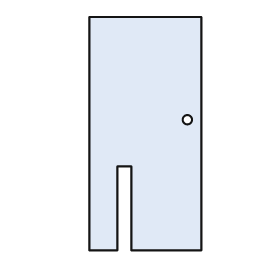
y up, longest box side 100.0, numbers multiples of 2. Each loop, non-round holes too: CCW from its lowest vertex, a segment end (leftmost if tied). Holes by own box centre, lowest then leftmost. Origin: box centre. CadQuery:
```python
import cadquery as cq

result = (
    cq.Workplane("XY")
    .moveTo(-24.0, -50.0)
    .lineTo(-12.0, -50.0)
    .lineTo(-12.0, -14.0)
    .lineTo(-6.0, -14.0)
    .lineTo(-6.0, -50.0)
    .lineTo(24.0, -50.0)
    .lineTo(24.0, 50.0)
    .lineTo(-24.0, 50.0)
    .close()
    .moveTo(18.0, 6.0)
    .circle(2.0)
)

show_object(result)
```